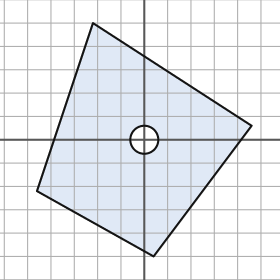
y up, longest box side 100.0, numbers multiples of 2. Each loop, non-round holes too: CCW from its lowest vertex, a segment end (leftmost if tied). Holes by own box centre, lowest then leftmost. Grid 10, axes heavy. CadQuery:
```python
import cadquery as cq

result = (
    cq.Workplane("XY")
    .moveTo(4.0, -50.0)
    .lineTo(46.0, 6.0)
    .lineTo(-22.0, 50.0)
    .lineTo(-46.0, -22.0)
    .close()
    .moveTo(0.0, 0.0)
    .circle(6.0)
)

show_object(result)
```